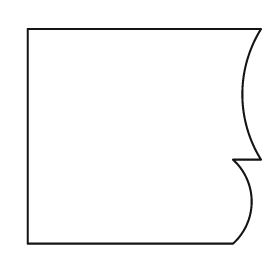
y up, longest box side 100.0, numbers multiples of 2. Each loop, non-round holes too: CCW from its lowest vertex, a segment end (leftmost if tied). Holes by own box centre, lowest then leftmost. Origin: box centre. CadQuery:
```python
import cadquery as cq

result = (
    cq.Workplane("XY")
    .moveTo(-50.0, -46.0)
    .lineTo(38.0, -46.0)
    .threePointArc((46.0, -28.0), (38.0, -10.0))
    .lineTo(50.0, -10.0)
    .threePointArc((42.0, 18.0), (50.0, 46.0))
    .lineTo(-50.0, 46.0)
    .close()
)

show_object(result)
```